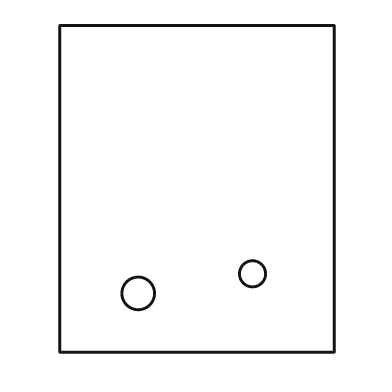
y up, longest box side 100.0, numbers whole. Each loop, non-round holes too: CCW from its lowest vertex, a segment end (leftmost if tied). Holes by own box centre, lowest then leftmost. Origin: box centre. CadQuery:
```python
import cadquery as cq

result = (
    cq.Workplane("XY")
    .moveTo(-42.0, -50.0)
    .lineTo(42.0, -50.0)
    .lineTo(42.0, 50.0)
    .lineTo(-42.0, 50.0)
    .close()
    .moveTo(-18.0, -32.0)
    .circle(5.0)
    .moveTo(17.0, -26.0)
    .circle(4.0)
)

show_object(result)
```